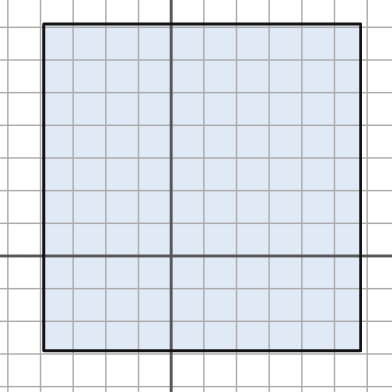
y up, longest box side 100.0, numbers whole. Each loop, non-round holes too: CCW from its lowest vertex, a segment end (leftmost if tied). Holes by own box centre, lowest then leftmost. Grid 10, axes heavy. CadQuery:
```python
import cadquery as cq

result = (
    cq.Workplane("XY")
    .moveTo(-39.0, -29.0)
    .lineTo(58.0, -29.0)
    .lineTo(58.0, 71.0)
    .lineTo(-39.0, 71.0)
    .close()
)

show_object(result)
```